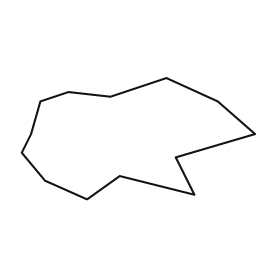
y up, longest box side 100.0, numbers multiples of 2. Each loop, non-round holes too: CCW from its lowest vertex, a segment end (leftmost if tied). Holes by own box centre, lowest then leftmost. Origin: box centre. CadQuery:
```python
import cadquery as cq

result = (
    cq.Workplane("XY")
    .moveTo(-22.0, -26.0)
    .lineTo(-8.0, -16.0)
    .lineTo(24.0, -24.0)
    .lineTo(16.0, -8.0)
    .lineTo(50.0, 2.0)
    .lineTo(34.0, 16.0)
    .lineTo(12.0, 26.0)
    .lineTo(-12.0, 18.0)
    .lineTo(-30.0, 20.0)
    .lineTo(-42.0, 16.0)
    .lineTo(-46.0, 2.0)
    .lineTo(-50.0, -6.0)
    .lineTo(-40.0, -18.0)
    .close()
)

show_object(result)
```